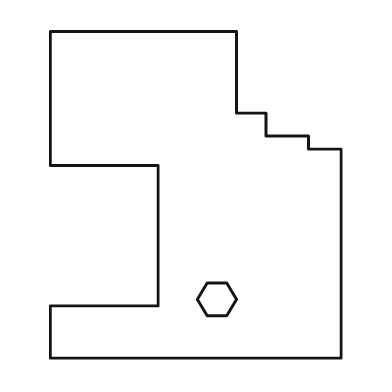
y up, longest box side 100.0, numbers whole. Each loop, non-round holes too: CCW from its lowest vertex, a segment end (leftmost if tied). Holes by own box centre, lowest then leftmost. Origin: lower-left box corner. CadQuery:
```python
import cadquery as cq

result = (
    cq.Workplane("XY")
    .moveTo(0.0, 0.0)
    .lineTo(89.0, 0.0)
    .lineTo(89.0, 64.0)
    .lineTo(79.0, 64.0)
    .lineTo(79.0, 68.0)
    .lineTo(66.0, 68.0)
    .lineTo(66.0, 75.0)
    .lineTo(57.0, 75.0)
    .lineTo(57.0, 100.0)
    .lineTo(0.0, 100.0)
    .lineTo(0.0, 59.0)
    .lineTo(33.0, 59.0)
    .lineTo(33.0, 16.0)
    .lineTo(0.0, 16.0)
    .close()
    .moveTo(48.0, 13.0)
    .lineTo(54.0, 13.0)
    .lineTo(57.0, 18.0)
    .lineTo(54.0, 23.0)
    .lineTo(48.0, 23.0)
    .lineTo(45.0, 18.0)
    .close()
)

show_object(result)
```